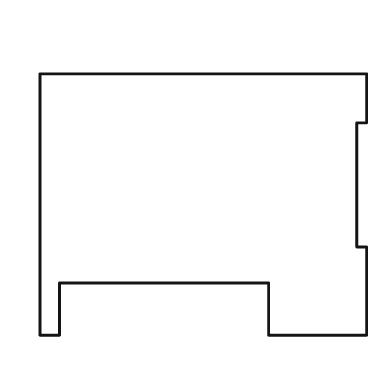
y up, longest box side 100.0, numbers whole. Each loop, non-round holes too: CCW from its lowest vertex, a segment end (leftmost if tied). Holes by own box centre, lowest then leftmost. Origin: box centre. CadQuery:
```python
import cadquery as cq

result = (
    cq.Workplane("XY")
    .moveTo(-50.0, -40.0)
    .lineTo(-44.0, -40.0)
    .lineTo(-44.0, -24.0)
    .lineTo(20.0, -24.0)
    .lineTo(20.0, -40.0)
    .lineTo(50.0, -40.0)
    .lineTo(50.0, -13.0)
    .lineTo(47.0, -13.0)
    .lineTo(47.0, 25.0)
    .lineTo(50.0, 25.0)
    .lineTo(50.0, 40.0)
    .lineTo(-50.0, 40.0)
    .close()
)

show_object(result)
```